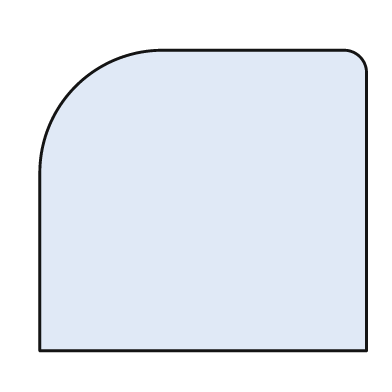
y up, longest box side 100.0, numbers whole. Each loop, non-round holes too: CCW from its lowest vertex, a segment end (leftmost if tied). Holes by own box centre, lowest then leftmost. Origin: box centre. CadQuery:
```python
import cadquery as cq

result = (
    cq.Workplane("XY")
    .moveTo(-50.0, -46.0)
    .lineTo(50.0, -46.0)
    .lineTo(50.0, 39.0)
    .threePointArc((48.0, 44.0), (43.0, 46.0))
    .lineTo(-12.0, 46.0)
    .threePointArc((-39.0, 35.0), (-50.0, 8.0))
    .close()
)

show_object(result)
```